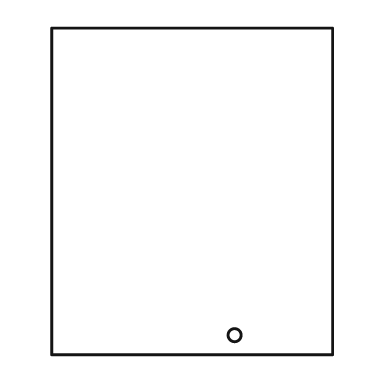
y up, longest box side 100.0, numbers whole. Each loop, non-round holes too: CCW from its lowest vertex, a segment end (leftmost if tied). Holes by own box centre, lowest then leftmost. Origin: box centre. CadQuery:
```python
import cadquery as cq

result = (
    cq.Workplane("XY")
    .moveTo(-43.0, -50.0)
    .lineTo(43.0, -50.0)
    .lineTo(43.0, 50.0)
    .lineTo(-43.0, 50.0)
    .close()
    .moveTo(13.0, -44.0)
    .circle(2.0)
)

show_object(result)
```